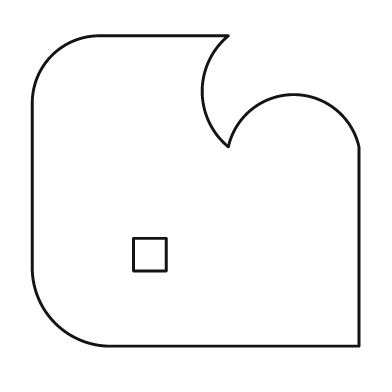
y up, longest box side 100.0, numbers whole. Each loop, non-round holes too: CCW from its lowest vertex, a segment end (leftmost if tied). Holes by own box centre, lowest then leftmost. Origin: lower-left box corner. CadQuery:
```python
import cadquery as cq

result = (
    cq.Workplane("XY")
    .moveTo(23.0, 0.0)
    .lineTo(100.0, 0.0)
    .lineTo(100.0, 61.0)
    .threePointArc((80.0, 77.0), (60.0, 61.0))
    .threePointArc((52.0, 78.0), (60.0, 95.0))
    .lineTo(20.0, 95.0)
    .threePointArc((6.0, 89.0), (0.0, 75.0))
    .lineTo(0.0, 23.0)
    .threePointArc((7.0, 7.0), (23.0, 0.0))
    .close()
    .moveTo(31.0, 23.0)
    .lineTo(41.0, 23.0)
    .lineTo(41.0, 33.0)
    .lineTo(31.0, 33.0)
    .close()
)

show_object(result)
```